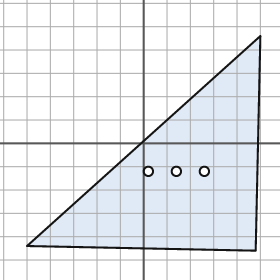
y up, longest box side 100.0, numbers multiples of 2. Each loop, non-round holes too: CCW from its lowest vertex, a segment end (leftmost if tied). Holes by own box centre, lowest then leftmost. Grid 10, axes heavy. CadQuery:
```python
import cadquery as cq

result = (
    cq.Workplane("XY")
    .moveTo(48.0, -46.0)
    .lineTo(50.0, 46.0)
    .lineTo(-50.0, -44.0)
    .close()
    .moveTo(2.0, -12.0)
    .circle(2.0)
    .moveTo(14.0, -12.0)
    .circle(2.0)
    .moveTo(26.0, -12.0)
    .circle(2.0)
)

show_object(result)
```